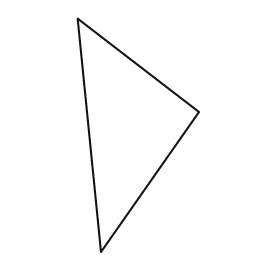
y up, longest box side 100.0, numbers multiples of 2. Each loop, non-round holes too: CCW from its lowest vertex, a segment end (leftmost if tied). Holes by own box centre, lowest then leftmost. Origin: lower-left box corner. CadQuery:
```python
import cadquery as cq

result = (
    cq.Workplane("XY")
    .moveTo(10.0, 0.0)
    .lineTo(52.0, 60.0)
    .lineTo(0.0, 100.0)
    .close()
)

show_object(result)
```